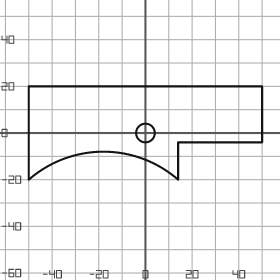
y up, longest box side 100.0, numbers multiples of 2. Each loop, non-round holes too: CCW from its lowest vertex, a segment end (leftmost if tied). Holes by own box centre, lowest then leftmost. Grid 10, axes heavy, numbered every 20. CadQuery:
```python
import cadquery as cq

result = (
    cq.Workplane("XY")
    .moveTo(-50.0, -20.0)
    .threePointArc((-18.0, -8.0), (14.0, -20.0))
    .lineTo(14.0, -4.0)
    .lineTo(50.0, -4.0)
    .lineTo(50.0, 20.0)
    .lineTo(-50.0, 20.0)
    .close()
    .moveTo(0.0, 0.0)
    .circle(4.0)
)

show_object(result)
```